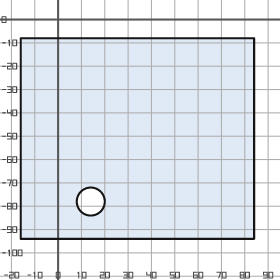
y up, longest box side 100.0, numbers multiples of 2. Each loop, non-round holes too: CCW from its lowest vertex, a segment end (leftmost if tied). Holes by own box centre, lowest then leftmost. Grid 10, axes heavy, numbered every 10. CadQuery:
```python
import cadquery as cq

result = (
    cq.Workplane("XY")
    .moveTo(-16.0, -94.0)
    .lineTo(84.0, -94.0)
    .lineTo(84.0, -8.0)
    .lineTo(-16.0, -8.0)
    .close()
    .moveTo(14.0, -78.0)
    .circle(6.0)
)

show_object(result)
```